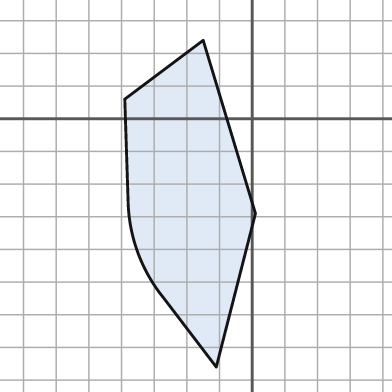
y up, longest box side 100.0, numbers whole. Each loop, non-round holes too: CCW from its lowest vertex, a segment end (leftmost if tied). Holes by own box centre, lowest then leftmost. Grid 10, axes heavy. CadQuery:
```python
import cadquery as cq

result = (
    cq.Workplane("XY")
    .moveTo(-11.0, -76.0)
    .lineTo(1.0, -29.0)
    .lineTo(-15.0, 24.0)
    .lineTo(-39.0, 6.0)
    .lineTo(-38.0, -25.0)
    .threePointArc((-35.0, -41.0), (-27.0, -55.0))
    .close()
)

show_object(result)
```